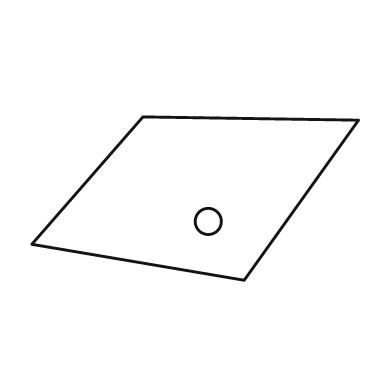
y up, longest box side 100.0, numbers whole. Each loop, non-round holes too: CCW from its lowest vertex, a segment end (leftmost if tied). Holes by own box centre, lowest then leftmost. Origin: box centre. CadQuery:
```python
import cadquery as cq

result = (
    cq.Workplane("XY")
    .moveTo(15.0, -25.0)
    .lineTo(50.0, 24.0)
    .lineTo(-16.0, 25.0)
    .lineTo(-50.0, -14.0)
    .close()
    .moveTo(4.0, -7.0)
    .circle(4.0)
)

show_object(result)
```